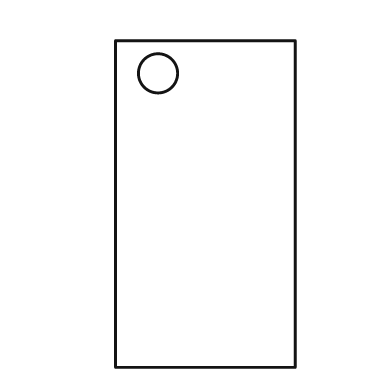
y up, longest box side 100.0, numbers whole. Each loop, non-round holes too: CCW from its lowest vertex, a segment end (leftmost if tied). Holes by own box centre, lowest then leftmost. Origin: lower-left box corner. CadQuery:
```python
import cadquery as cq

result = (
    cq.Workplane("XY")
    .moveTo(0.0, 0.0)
    .lineTo(55.0, 0.0)
    .lineTo(55.0, 100.0)
    .lineTo(0.0, 100.0)
    .close()
    .moveTo(13.0, 90.0)
    .circle(6.0)
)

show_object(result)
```